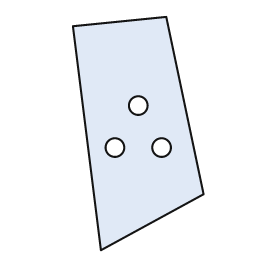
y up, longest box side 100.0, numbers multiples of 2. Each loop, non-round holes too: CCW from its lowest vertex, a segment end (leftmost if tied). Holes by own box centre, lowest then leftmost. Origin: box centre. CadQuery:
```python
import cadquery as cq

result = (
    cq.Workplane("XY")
    .moveTo(-16.0, -50.0)
    .lineTo(28.0, -26.0)
    .lineTo(12.0, 50.0)
    .lineTo(-28.0, 46.0)
    .close()
    .moveTo(-10.0, -6.0)
    .circle(4.0)
    .moveTo(10.0, -6.0)
    .circle(4.0)
    .moveTo(0.0, 12.0)
    .circle(4.0)
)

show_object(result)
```